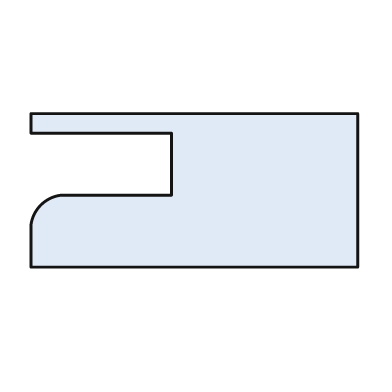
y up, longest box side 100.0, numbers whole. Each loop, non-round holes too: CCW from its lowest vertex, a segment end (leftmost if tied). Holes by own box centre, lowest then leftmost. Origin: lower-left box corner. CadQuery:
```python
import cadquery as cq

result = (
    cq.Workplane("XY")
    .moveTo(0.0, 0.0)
    .lineTo(100.0, 0.0)
    .lineTo(100.0, 47.0)
    .lineTo(0.0, 47.0)
    .lineTo(0.0, 41.0)
    .lineTo(43.0, 41.0)
    .lineTo(43.0, 22.0)
    .lineTo(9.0, 22.0)
    .threePointArc((3.0, 19.0), (0.0, 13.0))
    .close()
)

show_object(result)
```